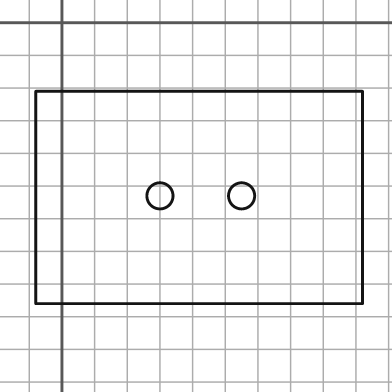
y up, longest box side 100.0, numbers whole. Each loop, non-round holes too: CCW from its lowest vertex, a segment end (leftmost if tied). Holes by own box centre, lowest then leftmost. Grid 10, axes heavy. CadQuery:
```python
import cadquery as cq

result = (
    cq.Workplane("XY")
    .moveTo(-8.0, -86.0)
    .lineTo(92.0, -86.0)
    .lineTo(92.0, -21.0)
    .lineTo(-8.0, -21.0)
    .close()
    .moveTo(30.0, -53.0)
    .circle(4.0)
    .moveTo(55.0, -53.0)
    .circle(4.0)
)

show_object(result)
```